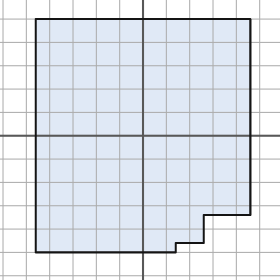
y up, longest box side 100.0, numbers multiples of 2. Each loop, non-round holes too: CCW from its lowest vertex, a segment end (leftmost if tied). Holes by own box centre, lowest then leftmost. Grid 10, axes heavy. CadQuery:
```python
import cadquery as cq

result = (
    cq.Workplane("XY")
    .moveTo(-46.0, -50.0)
    .lineTo(14.0, -50.0)
    .lineTo(14.0, -46.0)
    .lineTo(26.0, -46.0)
    .lineTo(26.0, -34.0)
    .lineTo(46.0, -34.0)
    .lineTo(46.0, 50.0)
    .lineTo(-46.0, 50.0)
    .close()
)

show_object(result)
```